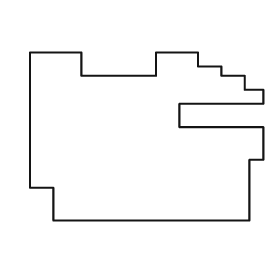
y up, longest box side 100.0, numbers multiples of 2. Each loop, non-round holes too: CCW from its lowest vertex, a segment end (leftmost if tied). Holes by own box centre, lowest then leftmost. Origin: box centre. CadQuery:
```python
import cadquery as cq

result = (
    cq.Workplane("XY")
    .moveTo(-40.0, -36.0)
    .lineTo(44.0, -36.0)
    .lineTo(44.0, -10.0)
    .lineTo(50.0, -10.0)
    .lineTo(50.0, 4.0)
    .lineTo(14.0, 4.0)
    .lineTo(14.0, 14.0)
    .lineTo(50.0, 14.0)
    .lineTo(50.0, 20.0)
    .lineTo(42.0, 20.0)
    .lineTo(42.0, 26.0)
    .lineTo(32.0, 26.0)
    .lineTo(32.0, 30.0)
    .lineTo(22.0, 30.0)
    .lineTo(22.0, 36.0)
    .lineTo(4.0, 36.0)
    .lineTo(4.0, 26.0)
    .lineTo(-28.0, 26.0)
    .lineTo(-28.0, 36.0)
    .lineTo(-50.0, 36.0)
    .lineTo(-50.0, -22.0)
    .lineTo(-40.0, -22.0)
    .close()
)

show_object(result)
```